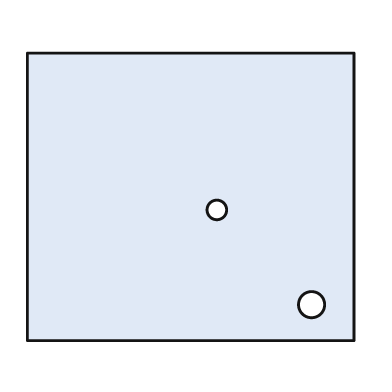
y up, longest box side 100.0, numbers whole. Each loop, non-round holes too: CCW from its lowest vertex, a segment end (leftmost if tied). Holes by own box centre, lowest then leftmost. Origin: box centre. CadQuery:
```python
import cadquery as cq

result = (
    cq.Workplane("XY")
    .moveTo(-50.0, -44.0)
    .lineTo(50.0, -44.0)
    .lineTo(50.0, 44.0)
    .lineTo(-50.0, 44.0)
    .close()
    .moveTo(37.0, -33.0)
    .circle(4.0)
    .moveTo(8.0, -4.0)
    .circle(3.0)
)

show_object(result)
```